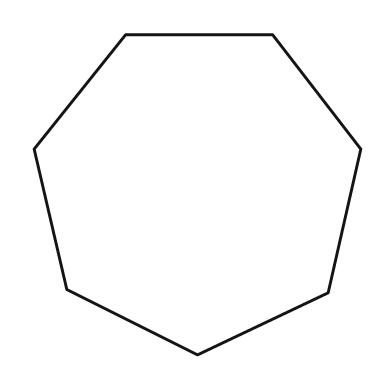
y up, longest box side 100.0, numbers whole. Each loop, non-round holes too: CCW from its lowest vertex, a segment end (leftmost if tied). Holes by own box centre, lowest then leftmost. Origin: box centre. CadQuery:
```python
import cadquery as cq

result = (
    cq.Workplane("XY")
    .moveTo(0.0, -49.0)
    .lineTo(40.0, -30.0)
    .lineTo(50.0, 14.0)
    .lineTo(23.0, 49.0)
    .lineTo(-22.0, 49.0)
    .lineTo(-50.0, 14.0)
    .lineTo(-40.0, -29.0)
    .close()
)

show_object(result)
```